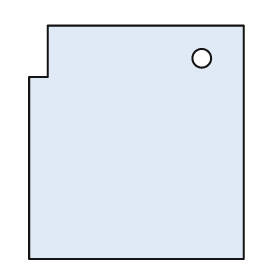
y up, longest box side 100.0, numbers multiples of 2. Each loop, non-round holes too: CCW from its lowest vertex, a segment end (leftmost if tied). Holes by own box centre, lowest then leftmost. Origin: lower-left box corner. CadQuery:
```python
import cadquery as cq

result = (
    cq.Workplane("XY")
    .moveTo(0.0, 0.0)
    .lineTo(92.0, 0.0)
    .lineTo(92.0, 100.0)
    .lineTo(8.0, 100.0)
    .lineTo(8.0, 78.0)
    .lineTo(0.0, 78.0)
    .close()
    .moveTo(74.0, 86.0)
    .circle(4.0)
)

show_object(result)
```